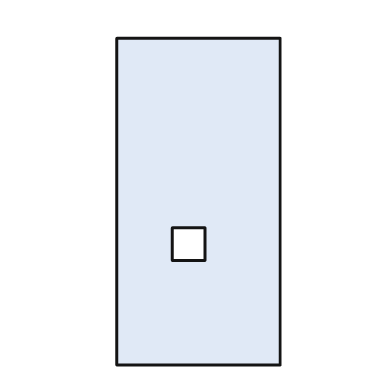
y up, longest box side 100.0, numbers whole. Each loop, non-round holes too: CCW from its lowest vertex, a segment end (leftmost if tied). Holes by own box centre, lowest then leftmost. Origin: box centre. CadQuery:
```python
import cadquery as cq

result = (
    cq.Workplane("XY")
    .moveTo(-25.0, -50.0)
    .lineTo(25.0, -50.0)
    .lineTo(25.0, 50.0)
    .lineTo(-25.0, 50.0)
    .close()
    .moveTo(-8.0, -18.0)
    .lineTo(2.0, -18.0)
    .lineTo(2.0, -8.0)
    .lineTo(-8.0, -8.0)
    .close()
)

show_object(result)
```